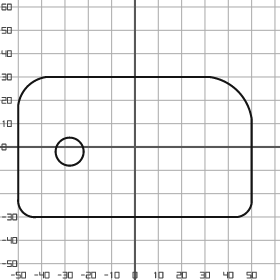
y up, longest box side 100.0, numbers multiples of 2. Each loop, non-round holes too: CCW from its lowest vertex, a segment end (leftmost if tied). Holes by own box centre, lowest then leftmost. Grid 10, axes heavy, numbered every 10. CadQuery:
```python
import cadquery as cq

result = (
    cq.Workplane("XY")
    .moveTo(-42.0, -30.0)
    .lineTo(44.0, -30.0)
    .threePointArc((48.0, -28.0), (50.0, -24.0))
    .lineTo(50.0, 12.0)
    .threePointArc((44.0, 24.0), (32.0, 30.0))
    .lineTo(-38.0, 30.0)
    .threePointArc((-46.0, 26.0), (-50.0, 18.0))
    .lineTo(-50.0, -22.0)
    .threePointArc((-48.0, -28.0), (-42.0, -30.0))
    .close()
    .moveTo(-28.0, -2.0)
    .circle(6.0)
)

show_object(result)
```